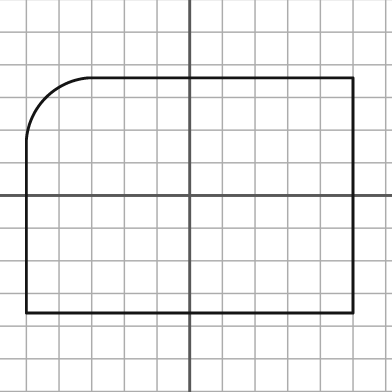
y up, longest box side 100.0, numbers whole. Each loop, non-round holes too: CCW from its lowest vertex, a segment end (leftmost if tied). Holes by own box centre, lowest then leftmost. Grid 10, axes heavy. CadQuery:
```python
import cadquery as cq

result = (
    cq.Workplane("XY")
    .moveTo(-50.0, -36.0)
    .lineTo(50.0, -36.0)
    .lineTo(50.0, 36.0)
    .lineTo(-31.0, 36.0)
    .threePointArc((-44.0, 30.0), (-50.0, 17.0))
    .close()
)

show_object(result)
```